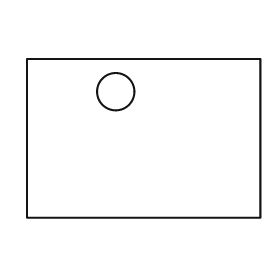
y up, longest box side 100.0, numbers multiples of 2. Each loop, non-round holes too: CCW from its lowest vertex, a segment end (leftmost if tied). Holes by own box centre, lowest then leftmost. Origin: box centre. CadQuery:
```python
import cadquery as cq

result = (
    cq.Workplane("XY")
    .moveTo(-50.0, -34.0)
    .lineTo(50.0, -34.0)
    .lineTo(50.0, 34.0)
    .lineTo(-50.0, 34.0)
    .close()
    .moveTo(-12.0, 20.0)
    .circle(8.0)
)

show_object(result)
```